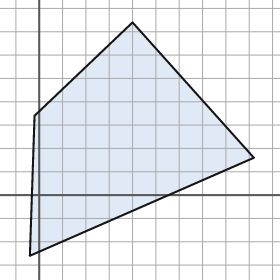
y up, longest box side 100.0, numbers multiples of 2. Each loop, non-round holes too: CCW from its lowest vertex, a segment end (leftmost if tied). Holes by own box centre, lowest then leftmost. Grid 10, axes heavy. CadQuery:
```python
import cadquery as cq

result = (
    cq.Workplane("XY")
    .moveTo(-4.0, -26.0)
    .lineTo(92.0, 16.0)
    .lineTo(40.0, 74.0)
    .lineTo(-2.0, 34.0)
    .close()
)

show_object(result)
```